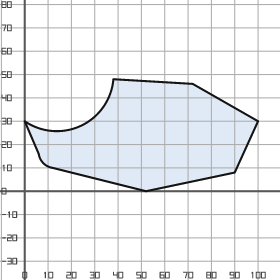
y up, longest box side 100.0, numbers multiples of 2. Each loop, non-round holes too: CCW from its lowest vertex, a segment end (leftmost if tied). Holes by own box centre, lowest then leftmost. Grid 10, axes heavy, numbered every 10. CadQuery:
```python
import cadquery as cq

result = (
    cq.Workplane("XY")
    .moveTo(52.0, 0.0)
    .lineTo(90.0, 8.0)
    .lineTo(100.0, 30.0)
    .lineTo(72.0, 46.0)
    .lineTo(38.0, 48.0)
    .threePointArc((24.0, 28.0), (0.0, 30.0))
    .lineTo(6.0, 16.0)
    .threePointArc((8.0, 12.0), (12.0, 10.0))
    .close()
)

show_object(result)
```